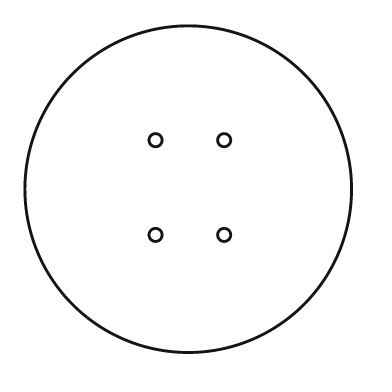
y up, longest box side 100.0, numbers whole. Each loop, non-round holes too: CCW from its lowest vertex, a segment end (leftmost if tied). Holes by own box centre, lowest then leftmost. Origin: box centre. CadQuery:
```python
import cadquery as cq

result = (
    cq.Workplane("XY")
    .moveTo(0.0, 0.0)
    .circle(50.0)
    .moveTo(-10.0, -14.0)
    .circle(2.0)
    .moveTo(11.0, -14.0)
    .circle(2.0)
    .moveTo(-10.0, 15.0)
    .circle(2.0)
    .moveTo(11.0, 15.0)
    .circle(2.0)
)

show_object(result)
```